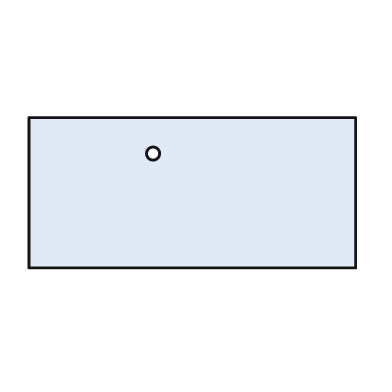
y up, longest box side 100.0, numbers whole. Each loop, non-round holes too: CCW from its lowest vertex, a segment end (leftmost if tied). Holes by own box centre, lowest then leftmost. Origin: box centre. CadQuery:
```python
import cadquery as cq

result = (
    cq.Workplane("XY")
    .moveTo(-50.0, -23.0)
    .lineTo(50.0, -23.0)
    .lineTo(50.0, 23.0)
    .lineTo(-50.0, 23.0)
    .close()
    .moveTo(-12.0, 12.0)
    .circle(2.0)
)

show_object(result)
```